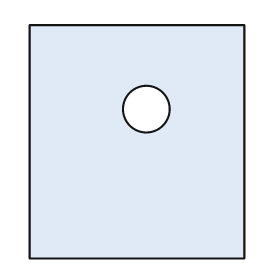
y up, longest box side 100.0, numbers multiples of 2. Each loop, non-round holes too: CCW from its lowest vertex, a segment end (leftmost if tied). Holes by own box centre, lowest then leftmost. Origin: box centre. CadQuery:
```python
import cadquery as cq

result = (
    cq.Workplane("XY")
    .moveTo(-46.0, -50.0)
    .lineTo(46.0, -50.0)
    .lineTo(46.0, 50.0)
    .lineTo(-46.0, 50.0)
    .close()
    .moveTo(4.0, 14.0)
    .circle(10.0)
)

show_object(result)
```